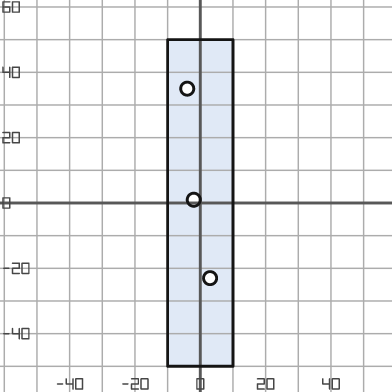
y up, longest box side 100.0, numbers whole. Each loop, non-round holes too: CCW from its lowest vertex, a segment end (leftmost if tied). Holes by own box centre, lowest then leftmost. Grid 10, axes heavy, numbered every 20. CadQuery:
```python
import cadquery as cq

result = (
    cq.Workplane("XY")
    .moveTo(-10.0, -50.0)
    .lineTo(10.0, -50.0)
    .lineTo(10.0, 50.0)
    .lineTo(-10.0, 50.0)
    .close()
    .moveTo(3.0, -23.0)
    .circle(2.0)
    .moveTo(-2.0, 1.0)
    .circle(2.0)
    .moveTo(-4.0, 35.0)
    .circle(2.0)
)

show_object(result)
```